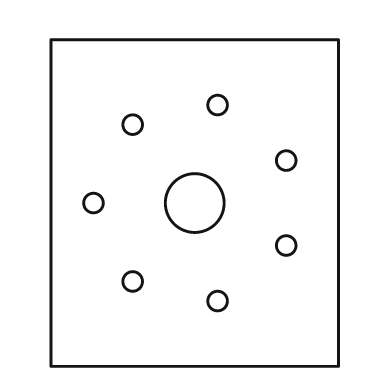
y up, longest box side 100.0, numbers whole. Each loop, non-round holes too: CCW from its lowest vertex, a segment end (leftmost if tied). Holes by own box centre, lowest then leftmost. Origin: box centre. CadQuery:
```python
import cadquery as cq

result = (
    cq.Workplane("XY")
    .moveTo(-44.0, -50.0)
    .lineTo(44.0, -50.0)
    .lineTo(44.0, 50.0)
    .lineTo(-44.0, 50.0)
    .close()
    .moveTo(7.0, -30.0)
    .circle(3.0)
    .moveTo(-19.0, -24.0)
    .circle(3.0)
    .moveTo(28.0, -13.0)
    .circle(3.0)
    .moveTo(-31.0, 0.0)
    .circle(3.0)
    .moveTo(0.0, 0.0)
    .circle(9.0)
    .moveTo(28.0, 13.0)
    .circle(3.0)
    .moveTo(-19.0, 24.0)
    .circle(3.0)
    .moveTo(7.0, 30.0)
    .circle(3.0)
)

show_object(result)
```